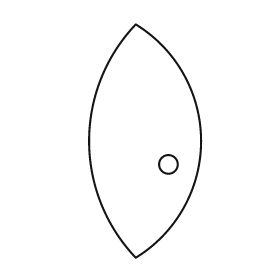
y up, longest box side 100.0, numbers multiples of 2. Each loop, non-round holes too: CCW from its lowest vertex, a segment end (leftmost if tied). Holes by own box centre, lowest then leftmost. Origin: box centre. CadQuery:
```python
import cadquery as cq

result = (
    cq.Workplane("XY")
    .moveTo(-4.0, -50.0)
    .threePointArc((24.0, 0.0), (-4.0, 50.0))
    .threePointArc((-24.0, 0.0), (-4.0, -50.0))
    .close()
    .moveTo(10.0, -10.0)
    .circle(4.0)
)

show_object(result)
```